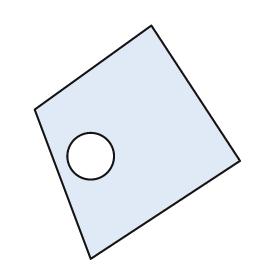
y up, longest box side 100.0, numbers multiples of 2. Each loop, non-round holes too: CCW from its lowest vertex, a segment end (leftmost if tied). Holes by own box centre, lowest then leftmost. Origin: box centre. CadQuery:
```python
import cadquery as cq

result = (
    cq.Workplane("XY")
    .moveTo(-20.0, -50.0)
    .lineTo(44.0, -8.0)
    .lineTo(6.0, 50.0)
    .lineTo(-44.0, 14.0)
    .close()
    .moveTo(-20.0, -6.0)
    .circle(10.0)
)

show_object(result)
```